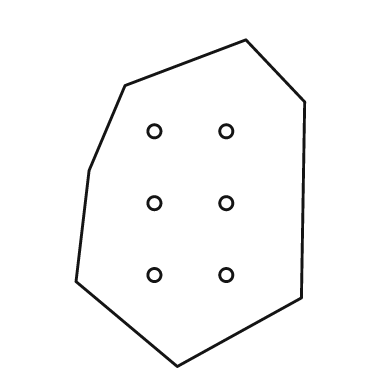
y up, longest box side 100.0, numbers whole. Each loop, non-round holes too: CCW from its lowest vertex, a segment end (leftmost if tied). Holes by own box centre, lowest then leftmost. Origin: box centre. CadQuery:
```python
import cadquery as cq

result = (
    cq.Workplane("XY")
    .moveTo(-4.0, -50.0)
    .lineTo(34.0, -29.0)
    .lineTo(35.0, 31.0)
    .lineTo(17.0, 50.0)
    .lineTo(-20.0, 36.0)
    .lineTo(-31.0, 10.0)
    .lineTo(-35.0, -24.0)
    .close()
    .moveTo(-11.0, -22.0)
    .circle(2.0)
    .moveTo(11.0, -22.0)
    .circle(2.0)
    .moveTo(-11.0, 0.0)
    .circle(2.0)
    .moveTo(11.0, 0.0)
    .circle(2.0)
    .moveTo(-11.0, 22.0)
    .circle(2.0)
    .moveTo(11.0, 22.0)
    .circle(2.0)
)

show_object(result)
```